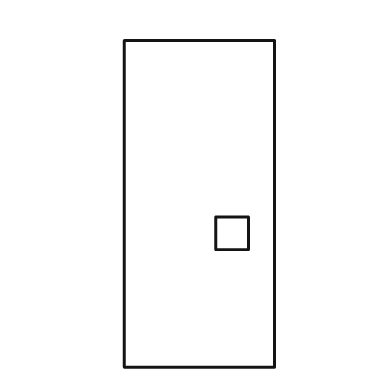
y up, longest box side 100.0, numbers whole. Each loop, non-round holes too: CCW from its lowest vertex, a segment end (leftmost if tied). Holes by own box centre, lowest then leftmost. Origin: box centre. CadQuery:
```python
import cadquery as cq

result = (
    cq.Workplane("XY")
    .moveTo(-23.0, -50.0)
    .lineTo(23.0, -50.0)
    .lineTo(23.0, 50.0)
    .lineTo(-23.0, 50.0)
    .close()
    .moveTo(5.0, -14.0)
    .lineTo(15.0, -14.0)
    .lineTo(15.0, -4.0)
    .lineTo(5.0, -4.0)
    .close()
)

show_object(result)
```